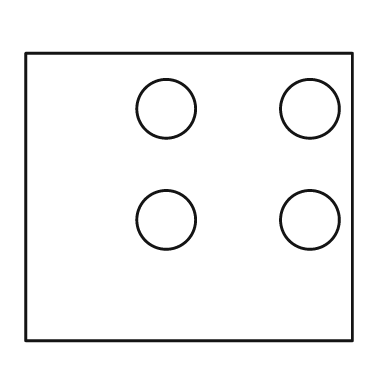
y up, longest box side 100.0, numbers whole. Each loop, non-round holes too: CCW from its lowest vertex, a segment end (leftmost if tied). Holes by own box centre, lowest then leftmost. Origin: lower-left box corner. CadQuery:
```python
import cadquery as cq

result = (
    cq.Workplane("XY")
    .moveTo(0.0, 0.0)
    .lineTo(100.0, 0.0)
    .lineTo(100.0, 88.0)
    .lineTo(0.0, 88.0)
    .close()
    .moveTo(43.0, 37.0)
    .circle(9.0)
    .moveTo(87.0, 37.0)
    .circle(9.0)
    .moveTo(43.0, 71.0)
    .circle(9.0)
    .moveTo(87.0, 71.0)
    .circle(9.0)
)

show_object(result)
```